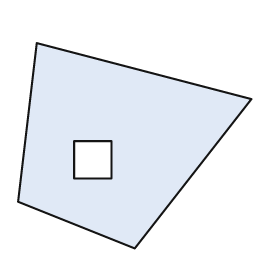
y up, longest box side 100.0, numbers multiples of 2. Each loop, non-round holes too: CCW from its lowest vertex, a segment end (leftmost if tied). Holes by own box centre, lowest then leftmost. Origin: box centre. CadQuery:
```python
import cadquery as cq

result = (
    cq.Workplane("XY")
    .moveTo(0.0, -44.0)
    .lineTo(50.0, 20.0)
    .lineTo(-42.0, 44.0)
    .lineTo(-50.0, -24.0)
    .close()
    .moveTo(-26.0, -14.0)
    .lineTo(-10.0, -14.0)
    .lineTo(-10.0, 2.0)
    .lineTo(-26.0, 2.0)
    .close()
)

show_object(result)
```